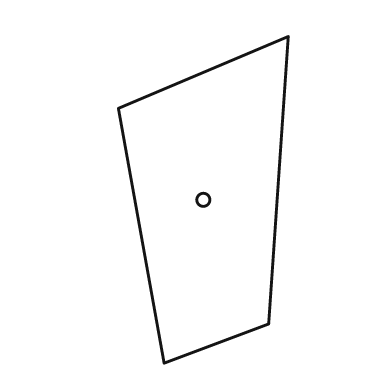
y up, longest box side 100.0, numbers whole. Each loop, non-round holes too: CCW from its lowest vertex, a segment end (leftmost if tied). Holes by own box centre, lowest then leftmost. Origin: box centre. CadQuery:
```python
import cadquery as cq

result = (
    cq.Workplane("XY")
    .moveTo(-12.0, -50.0)
    .lineTo(20.0, -38.0)
    .lineTo(26.0, 50.0)
    .lineTo(-26.0, 28.0)
    .close()
    .moveTo(0.0, 0.0)
    .circle(2.0)
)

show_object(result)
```